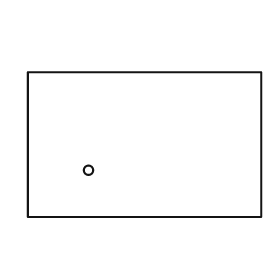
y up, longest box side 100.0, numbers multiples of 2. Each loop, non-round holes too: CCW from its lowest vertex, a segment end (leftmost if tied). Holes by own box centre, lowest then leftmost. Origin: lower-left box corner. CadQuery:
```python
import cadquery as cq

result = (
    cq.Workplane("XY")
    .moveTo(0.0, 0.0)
    .lineTo(100.0, 0.0)
    .lineTo(100.0, 62.0)
    .lineTo(0.0, 62.0)
    .close()
    .moveTo(26.0, 20.0)
    .circle(2.0)
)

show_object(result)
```